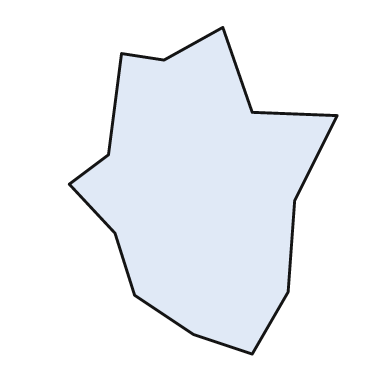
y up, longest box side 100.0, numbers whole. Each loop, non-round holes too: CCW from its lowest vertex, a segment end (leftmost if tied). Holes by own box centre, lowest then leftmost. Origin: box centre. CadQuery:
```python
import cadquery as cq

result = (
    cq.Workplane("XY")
    .moveTo(15.0, -50.0)
    .lineTo(26.0, -31.0)
    .lineTo(28.0, -3.0)
    .lineTo(41.0, 23.0)
    .lineTo(15.0, 24.0)
    .lineTo(6.0, 50.0)
    .lineTo(-12.0, 40.0)
    .lineTo(-25.0, 42.0)
    .lineTo(-29.0, 11.0)
    .lineTo(-41.0, 2.0)
    .lineTo(-27.0, -13.0)
    .lineTo(-21.0, -32.0)
    .lineTo(-3.0, -44.0)
    .close()
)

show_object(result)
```